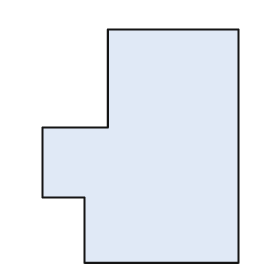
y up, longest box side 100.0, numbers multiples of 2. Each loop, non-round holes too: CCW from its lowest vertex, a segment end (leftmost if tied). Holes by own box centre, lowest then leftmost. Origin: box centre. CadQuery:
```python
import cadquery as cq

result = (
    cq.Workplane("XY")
    .moveTo(-24.0, -50.0)
    .lineTo(42.0, -50.0)
    .lineTo(42.0, 50.0)
    .lineTo(-14.0, 50.0)
    .lineTo(-14.0, 8.0)
    .lineTo(-42.0, 8.0)
    .lineTo(-42.0, -22.0)
    .lineTo(-24.0, -22.0)
    .close()
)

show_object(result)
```